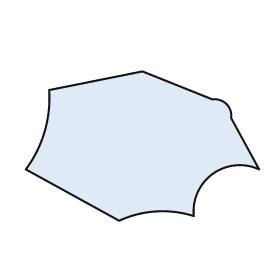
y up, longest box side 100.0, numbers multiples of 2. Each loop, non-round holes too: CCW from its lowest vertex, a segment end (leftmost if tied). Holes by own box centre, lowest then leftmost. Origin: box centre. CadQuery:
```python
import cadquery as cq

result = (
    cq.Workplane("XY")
    .moveTo(-10.0, -32.0)
    .threePointArc((6.0, -28.0), (22.0, -30.0))
    .threePointArc((30.0, -12.0), (50.0, -10.0))
    .lineTo(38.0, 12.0)
    .threePointArc((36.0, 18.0), (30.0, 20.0))
    .lineTo(0.0, 32.0)
    .lineTo(-40.0, 24.0)
    .threePointArc((-42.0, 6.0), (-50.0, -10.0))
    .close()
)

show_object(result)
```